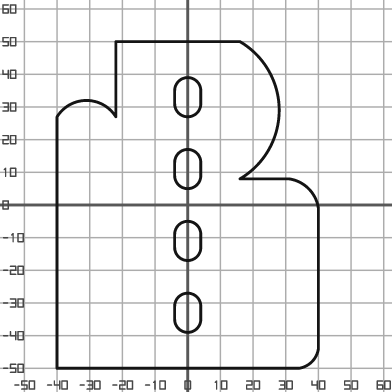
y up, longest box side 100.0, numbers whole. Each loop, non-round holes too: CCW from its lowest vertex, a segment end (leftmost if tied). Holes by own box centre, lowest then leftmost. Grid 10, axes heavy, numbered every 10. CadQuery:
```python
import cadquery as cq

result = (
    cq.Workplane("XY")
    .moveTo(-40.0, -50.0)
    .lineTo(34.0, -50.0)
    .threePointArc((38.0, -48.0), (40.0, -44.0))
    .lineTo(40.0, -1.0)
    .threePointArc((37.0, 5.0), (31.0, 8.0))
    .lineTo(16.0, 8.0)
    .threePointArc((28.0, 29.0), (16.0, 50.0))
    .lineTo(-22.0, 50.0)
    .lineTo(-22.0, 27.0)
    .threePointArc((-31.0, 32.0), (-40.0, 27.0))
    .close()
    .moveTo(-4.0, -35.0)
    .threePointArc((0.0, -39.0), (4.0, -35.0))
    .lineTo(4.0, -31.0)
    .threePointArc((0.0, -27.0), (-4.0, -31.0))
    .close()
    .moveTo(-4.0, -13.0)
    .threePointArc((0.0, -17.0), (4.0, -13.0))
    .lineTo(4.0, -9.0)
    .threePointArc((0.0, -5.0), (-4.0, -9.0))
    .close()
    .moveTo(-4.0, 9.0)
    .threePointArc((0.0, 5.0), (4.0, 9.0))
    .lineTo(4.0, 13.0)
    .threePointArc((0.0, 17.0), (-4.0, 13.0))
    .close()
    .moveTo(-4.0, 31.0)
    .threePointArc((0.0, 27.0), (4.0, 31.0))
    .lineTo(4.0, 35.0)
    .threePointArc((0.0, 39.0), (-4.0, 35.0))
    .close()
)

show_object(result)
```